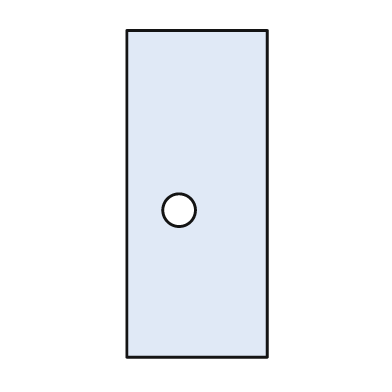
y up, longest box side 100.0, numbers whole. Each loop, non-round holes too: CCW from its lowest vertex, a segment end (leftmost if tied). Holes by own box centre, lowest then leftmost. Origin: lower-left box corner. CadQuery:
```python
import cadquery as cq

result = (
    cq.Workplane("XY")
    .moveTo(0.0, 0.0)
    .lineTo(43.0, 0.0)
    .lineTo(43.0, 100.0)
    .lineTo(0.0, 100.0)
    .close()
    .moveTo(16.0, 45.0)
    .circle(5.0)
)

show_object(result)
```